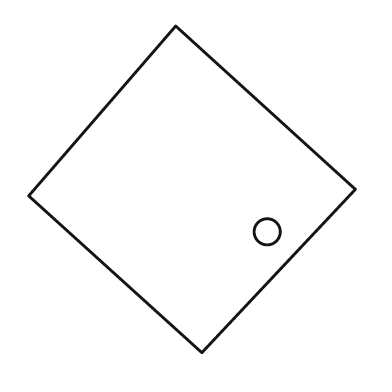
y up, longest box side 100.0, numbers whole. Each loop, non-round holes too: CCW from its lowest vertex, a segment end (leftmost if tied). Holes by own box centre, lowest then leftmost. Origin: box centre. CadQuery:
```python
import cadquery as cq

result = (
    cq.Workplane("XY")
    .moveTo(3.0, -50.0)
    .lineTo(50.0, 0.0)
    .lineTo(-5.0, 50.0)
    .lineTo(-50.0, -2.0)
    .close()
    .moveTo(23.0, -13.0)
    .circle(4.0)
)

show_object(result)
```